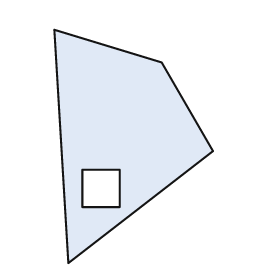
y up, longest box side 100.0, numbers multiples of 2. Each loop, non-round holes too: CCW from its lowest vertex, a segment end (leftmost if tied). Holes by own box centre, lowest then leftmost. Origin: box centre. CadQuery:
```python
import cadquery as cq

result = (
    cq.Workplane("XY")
    .moveTo(-28.0, -50.0)
    .lineTo(34.0, -2.0)
    .lineTo(12.0, 36.0)
    .lineTo(-34.0, 50.0)
    .close()
    .moveTo(-22.0, -26.0)
    .lineTo(-6.0, -26.0)
    .lineTo(-6.0, -10.0)
    .lineTo(-22.0, -10.0)
    .close()
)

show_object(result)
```